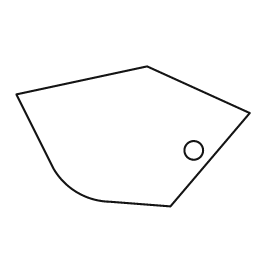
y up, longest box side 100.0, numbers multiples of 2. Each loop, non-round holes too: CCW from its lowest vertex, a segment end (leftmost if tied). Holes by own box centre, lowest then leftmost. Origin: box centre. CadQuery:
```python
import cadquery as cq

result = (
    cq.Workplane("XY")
    .moveTo(16.0, -30.0)
    .lineTo(50.0, 10.0)
    .lineTo(6.0, 30.0)
    .lineTo(-50.0, 18.0)
    .lineTo(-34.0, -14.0)
    .threePointArc((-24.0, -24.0), (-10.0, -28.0))
    .close()
    .moveTo(26.0, -6.0)
    .circle(4.0)
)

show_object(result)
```